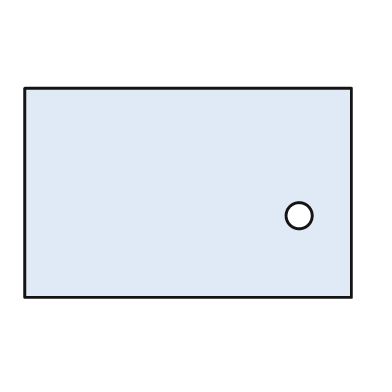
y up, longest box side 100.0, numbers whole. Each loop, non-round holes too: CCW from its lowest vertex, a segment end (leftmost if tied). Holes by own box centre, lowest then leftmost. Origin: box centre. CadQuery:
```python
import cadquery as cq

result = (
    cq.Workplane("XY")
    .moveTo(-50.0, -32.0)
    .lineTo(50.0, -32.0)
    .lineTo(50.0, 32.0)
    .lineTo(-50.0, 32.0)
    .close()
    .moveTo(34.0, -7.0)
    .circle(4.0)
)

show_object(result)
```